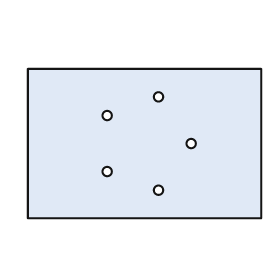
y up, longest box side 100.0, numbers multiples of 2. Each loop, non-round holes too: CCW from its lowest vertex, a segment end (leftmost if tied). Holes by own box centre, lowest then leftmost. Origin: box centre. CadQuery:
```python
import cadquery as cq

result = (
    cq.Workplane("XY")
    .moveTo(-50.0, -32.0)
    .lineTo(50.0, -32.0)
    .lineTo(50.0, 32.0)
    .lineTo(-50.0, 32.0)
    .close()
    .moveTo(6.0, -20.0)
    .circle(2.0)
    .moveTo(-16.0, -12.0)
    .circle(2.0)
    .moveTo(20.0, 0.0)
    .circle(2.0)
    .moveTo(-16.0, 12.0)
    .circle(2.0)
    .moveTo(6.0, 20.0)
    .circle(2.0)
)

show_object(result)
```